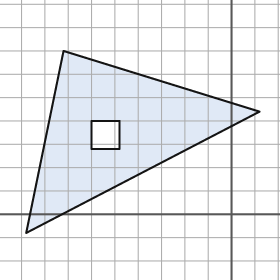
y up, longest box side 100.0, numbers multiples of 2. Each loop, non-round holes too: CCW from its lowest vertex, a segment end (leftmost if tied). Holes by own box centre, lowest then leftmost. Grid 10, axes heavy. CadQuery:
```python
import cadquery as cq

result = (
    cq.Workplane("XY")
    .moveTo(-88.0, -8.0)
    .lineTo(12.0, 44.0)
    .lineTo(-72.0, 70.0)
    .close()
    .moveTo(-60.0, 28.0)
    .lineTo(-48.0, 28.0)
    .lineTo(-48.0, 40.0)
    .lineTo(-60.0, 40.0)
    .close()
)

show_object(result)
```